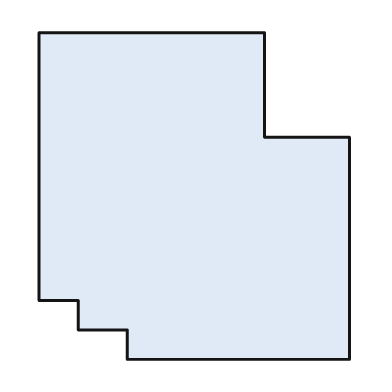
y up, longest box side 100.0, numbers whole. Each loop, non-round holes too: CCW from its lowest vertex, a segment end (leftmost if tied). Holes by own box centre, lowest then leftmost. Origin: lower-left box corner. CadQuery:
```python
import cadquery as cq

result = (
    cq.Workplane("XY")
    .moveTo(27.0, 0.0)
    .lineTo(95.0, 0.0)
    .lineTo(95.0, 68.0)
    .lineTo(69.0, 68.0)
    .lineTo(69.0, 100.0)
    .lineTo(0.0, 100.0)
    .lineTo(0.0, 18.0)
    .lineTo(12.0, 18.0)
    .lineTo(12.0, 9.0)
    .lineTo(27.0, 9.0)
    .close()
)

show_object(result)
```